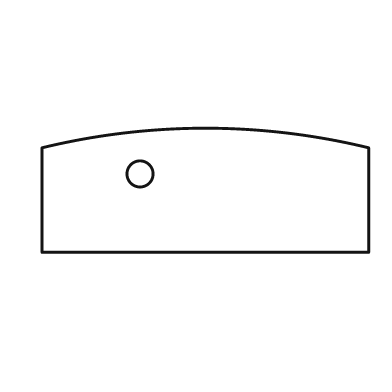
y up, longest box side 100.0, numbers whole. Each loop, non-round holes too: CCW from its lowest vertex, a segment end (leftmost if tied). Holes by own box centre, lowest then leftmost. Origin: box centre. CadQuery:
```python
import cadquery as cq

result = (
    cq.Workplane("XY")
    .moveTo(-50.0, -19.0)
    .lineTo(50.0, -19.0)
    .lineTo(50.0, 13.0)
    .threePointArc((0.0, 19.0), (-50.0, 13.0))
    .close()
    .moveTo(-20.0, 5.0)
    .circle(4.0)
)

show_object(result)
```